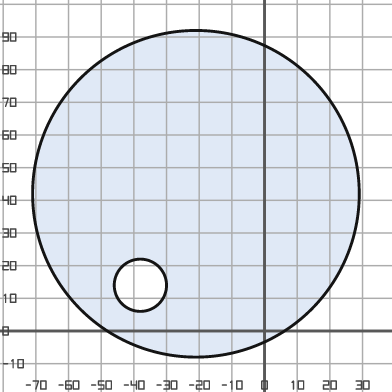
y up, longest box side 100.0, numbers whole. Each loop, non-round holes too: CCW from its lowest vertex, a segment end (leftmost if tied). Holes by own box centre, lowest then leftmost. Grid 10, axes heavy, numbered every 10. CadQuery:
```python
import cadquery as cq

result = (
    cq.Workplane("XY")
    .moveTo(-21.0, 42.0)
    .circle(50.0)
    .moveTo(-38.0, 14.0)
    .circle(8.0)
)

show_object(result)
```